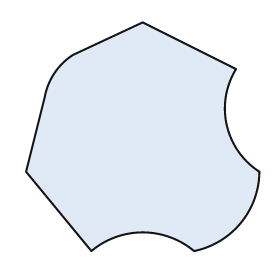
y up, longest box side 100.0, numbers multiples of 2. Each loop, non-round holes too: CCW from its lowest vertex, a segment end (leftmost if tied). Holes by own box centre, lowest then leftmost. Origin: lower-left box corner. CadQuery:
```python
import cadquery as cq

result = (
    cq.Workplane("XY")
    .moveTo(28.0, 0.0)
    .threePointArc((50.0, 8.0), (72.0, 0.0))
    .threePointArc((92.0, 12.0), (100.0, 34.0))
    .threePointArc((86.0, 54.0), (90.0, 78.0))
    .lineTo(50.0, 98.0)
    .lineTo(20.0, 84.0)
    .threePointArc((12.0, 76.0), (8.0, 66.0))
    .lineTo(0.0, 34.0)
    .close()
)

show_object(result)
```